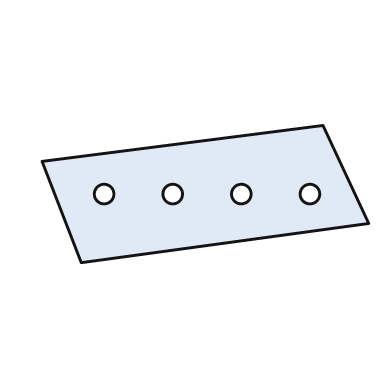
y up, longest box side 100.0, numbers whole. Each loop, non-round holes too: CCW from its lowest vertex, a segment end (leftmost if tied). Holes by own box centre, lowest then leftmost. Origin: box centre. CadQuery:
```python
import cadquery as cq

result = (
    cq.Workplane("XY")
    .moveTo(-38.0, -21.0)
    .lineTo(50.0, -9.0)
    .lineTo(36.0, 21.0)
    .lineTo(-50.0, 10.0)
    .close()
    .moveTo(-31.0, 0.0)
    .circle(3.0)
    .moveTo(-10.0, 0.0)
    .circle(3.0)
    .moveTo(11.0, 0.0)
    .circle(3.0)
    .moveTo(32.0, 0.0)
    .circle(3.0)
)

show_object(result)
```